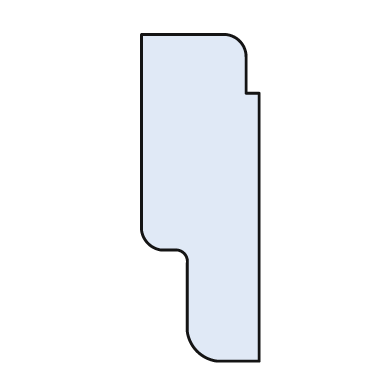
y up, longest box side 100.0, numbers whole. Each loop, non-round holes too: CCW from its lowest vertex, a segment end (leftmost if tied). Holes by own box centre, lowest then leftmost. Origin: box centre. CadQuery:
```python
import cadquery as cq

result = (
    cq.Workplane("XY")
    .moveTo(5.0, -50.0)
    .lineTo(18.0, -50.0)
    .lineTo(18.0, 32.0)
    .lineTo(14.0, 32.0)
    .lineTo(14.0, 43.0)
    .threePointArc((12.0, 48.0), (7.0, 50.0))
    .lineTo(-18.0, 50.0)
    .lineTo(-18.0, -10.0)
    .threePointArc((-16.0, -14.0), (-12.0, -16.0))
    .lineTo(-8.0, -16.0)
    .threePointArc((-5.0, -17.0), (-4.0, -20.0))
    .lineTo(-4.0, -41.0)
    .threePointArc((-1.0, -47.0), (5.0, -50.0))
    .close()
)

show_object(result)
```